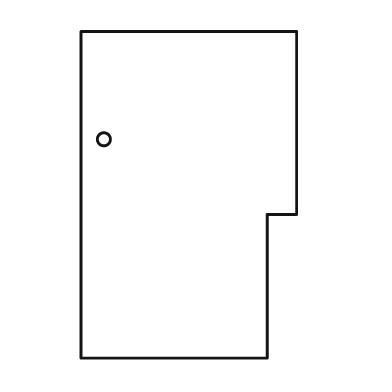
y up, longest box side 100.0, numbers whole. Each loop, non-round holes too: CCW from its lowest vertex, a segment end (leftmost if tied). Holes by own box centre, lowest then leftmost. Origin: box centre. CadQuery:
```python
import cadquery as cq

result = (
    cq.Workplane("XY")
    .moveTo(-33.0, -50.0)
    .lineTo(24.0, -50.0)
    .lineTo(24.0, -6.0)
    .lineTo(33.0, -6.0)
    .lineTo(33.0, 50.0)
    .lineTo(-33.0, 50.0)
    .close()
    .moveTo(-26.0, 17.0)
    .circle(2.0)
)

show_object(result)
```